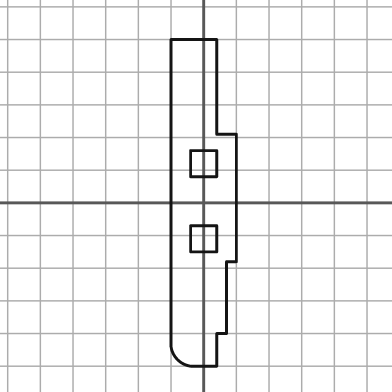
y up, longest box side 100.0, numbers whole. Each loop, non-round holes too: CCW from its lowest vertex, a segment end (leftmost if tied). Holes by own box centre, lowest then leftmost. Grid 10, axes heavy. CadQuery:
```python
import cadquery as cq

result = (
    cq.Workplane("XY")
    .moveTo(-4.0, -50.0)
    .lineTo(4.0, -50.0)
    .lineTo(4.0, -40.0)
    .lineTo(7.0, -40.0)
    .lineTo(7.0, -18.0)
    .lineTo(10.0, -18.0)
    .lineTo(10.0, 21.0)
    .lineTo(4.0, 21.0)
    .lineTo(4.0, 50.0)
    .lineTo(-10.0, 50.0)
    .lineTo(-10.0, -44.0)
    .threePointArc((-8.0, -48.0), (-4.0, -50.0))
    .close()
    .moveTo(-4.0, -15.0)
    .lineTo(4.0, -15.0)
    .lineTo(4.0, -7.0)
    .lineTo(-4.0, -7.0)
    .close()
    .moveTo(-4.0, 8.0)
    .lineTo(4.0, 8.0)
    .lineTo(4.0, 16.0)
    .lineTo(-4.0, 16.0)
    .close()
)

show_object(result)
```